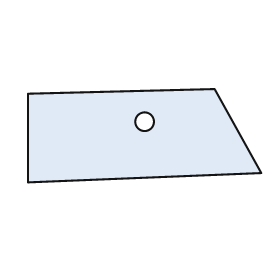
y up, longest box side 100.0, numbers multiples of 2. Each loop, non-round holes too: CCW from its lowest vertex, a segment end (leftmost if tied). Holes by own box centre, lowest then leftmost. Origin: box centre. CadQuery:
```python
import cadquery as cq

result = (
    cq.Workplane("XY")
    .moveTo(-50.0, -20.0)
    .lineTo(50.0, -16.0)
    .lineTo(30.0, 20.0)
    .lineTo(-50.0, 18.0)
    .close()
    .moveTo(0.0, 6.0)
    .circle(4.0)
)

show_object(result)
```